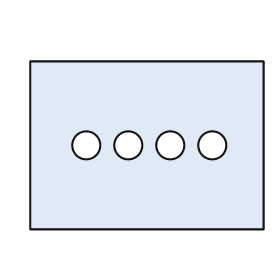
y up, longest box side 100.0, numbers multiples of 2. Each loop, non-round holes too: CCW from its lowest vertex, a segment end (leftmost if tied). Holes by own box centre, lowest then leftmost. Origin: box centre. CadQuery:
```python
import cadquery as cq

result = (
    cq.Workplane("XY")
    .moveTo(-50.0, -36.0)
    .lineTo(50.0, -36.0)
    .lineTo(50.0, 36.0)
    .lineTo(-50.0, 36.0)
    .close()
    .moveTo(-26.0, 0.0)
    .circle(6.0)
    .moveTo(-8.0, 0.0)
    .circle(6.0)
    .moveTo(10.0, 0.0)
    .circle(6.0)
    .moveTo(28.0, 0.0)
    .circle(6.0)
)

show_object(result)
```